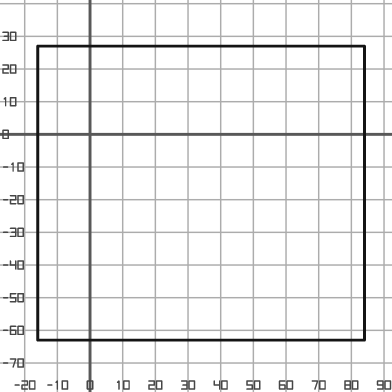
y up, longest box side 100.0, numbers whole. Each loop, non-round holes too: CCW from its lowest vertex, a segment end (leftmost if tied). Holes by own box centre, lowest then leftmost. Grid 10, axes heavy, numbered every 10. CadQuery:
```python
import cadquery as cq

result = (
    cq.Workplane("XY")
    .moveTo(-16.0, -63.0)
    .lineTo(84.0, -63.0)
    .lineTo(84.0, 27.0)
    .lineTo(-16.0, 27.0)
    .close()
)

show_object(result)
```